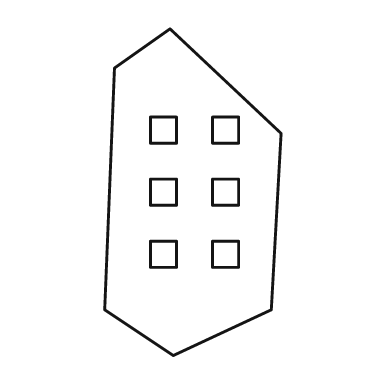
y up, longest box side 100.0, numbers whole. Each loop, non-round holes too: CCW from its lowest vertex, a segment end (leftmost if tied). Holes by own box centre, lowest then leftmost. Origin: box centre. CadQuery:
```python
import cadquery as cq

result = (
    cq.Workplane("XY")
    .moveTo(-6.0, -50.0)
    .lineTo(24.0, -36.0)
    .lineTo(27.0, 18.0)
    .lineTo(-7.0, 50.0)
    .lineTo(-24.0, 38.0)
    .lineTo(-27.0, -36.0)
    .close()
    .moveTo(-13.0, -23.0)
    .lineTo(-5.0, -23.0)
    .lineTo(-5.0, -15.0)
    .lineTo(-13.0, -15.0)
    .close()
    .moveTo(6.0, -23.0)
    .lineTo(14.0, -23.0)
    .lineTo(14.0, -15.0)
    .lineTo(6.0, -15.0)
    .close()
    .moveTo(-13.0, -4.0)
    .lineTo(-5.0, -4.0)
    .lineTo(-5.0, 4.0)
    .lineTo(-13.0, 4.0)
    .close()
    .moveTo(6.0, -4.0)
    .lineTo(14.0, -4.0)
    .lineTo(14.0, 4.0)
    .lineTo(6.0, 4.0)
    .close()
    .moveTo(-13.0, 15.0)
    .lineTo(-5.0, 15.0)
    .lineTo(-5.0, 23.0)
    .lineTo(-13.0, 23.0)
    .close()
    .moveTo(6.0, 15.0)
    .lineTo(14.0, 15.0)
    .lineTo(14.0, 23.0)
    .lineTo(6.0, 23.0)
    .close()
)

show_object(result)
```